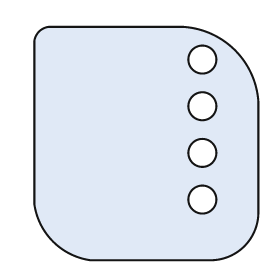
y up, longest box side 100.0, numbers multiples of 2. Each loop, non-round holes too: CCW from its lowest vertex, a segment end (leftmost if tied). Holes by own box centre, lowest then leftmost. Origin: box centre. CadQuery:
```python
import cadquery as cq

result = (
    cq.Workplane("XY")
    .moveTo(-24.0, -50.0)
    .lineTo(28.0, -50.0)
    .threePointArc((42.0, -44.0), (48.0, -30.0))
    .lineTo(48.0, 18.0)
    .threePointArc((38.0, 40.0), (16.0, 50.0))
    .lineTo(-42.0, 50.0)
    .threePointArc((-46.0, 48.0), (-48.0, 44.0))
    .lineTo(-48.0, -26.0)
    .threePointArc((-40.0, -42.0), (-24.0, -50.0))
    .close()
    .moveTo(24.0, -24.0)
    .circle(6.0)
    .moveTo(24.0, -4.0)
    .circle(6.0)
    .moveTo(24.0, 16.0)
    .circle(6.0)
    .moveTo(24.0, 36.0)
    .circle(6.0)
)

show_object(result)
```